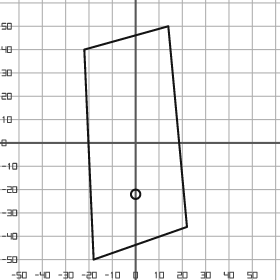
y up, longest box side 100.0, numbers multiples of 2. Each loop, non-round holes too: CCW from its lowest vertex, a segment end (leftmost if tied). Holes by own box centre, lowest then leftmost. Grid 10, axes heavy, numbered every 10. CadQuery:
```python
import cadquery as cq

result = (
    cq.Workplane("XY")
    .moveTo(-18.0, -50.0)
    .lineTo(22.0, -36.0)
    .lineTo(14.0, 50.0)
    .lineTo(-22.0, 40.0)
    .close()
    .moveTo(0.0, -22.0)
    .circle(2.0)
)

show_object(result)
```